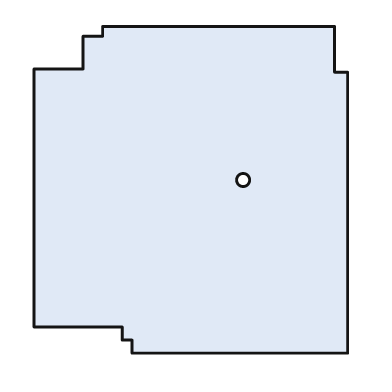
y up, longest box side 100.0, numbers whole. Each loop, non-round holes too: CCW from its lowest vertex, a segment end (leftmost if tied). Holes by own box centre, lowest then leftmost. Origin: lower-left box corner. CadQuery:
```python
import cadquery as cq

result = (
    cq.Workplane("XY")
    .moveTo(30.0, 0.0)
    .lineTo(96.0, 0.0)
    .lineTo(96.0, 86.0)
    .lineTo(92.0, 86.0)
    .lineTo(92.0, 100.0)
    .lineTo(21.0, 100.0)
    .lineTo(21.0, 97.0)
    .lineTo(15.0, 97.0)
    .lineTo(15.0, 87.0)
    .lineTo(0.0, 87.0)
    .lineTo(0.0, 8.0)
    .lineTo(27.0, 8.0)
    .lineTo(27.0, 4.0)
    .lineTo(30.0, 4.0)
    .close()
    .moveTo(64.0, 53.0)
    .circle(2.0)
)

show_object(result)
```